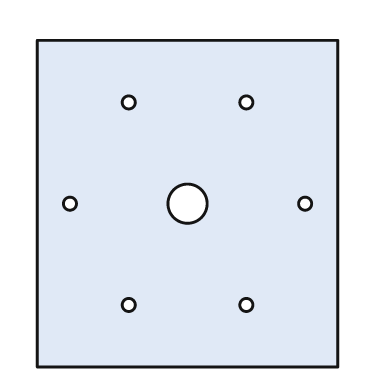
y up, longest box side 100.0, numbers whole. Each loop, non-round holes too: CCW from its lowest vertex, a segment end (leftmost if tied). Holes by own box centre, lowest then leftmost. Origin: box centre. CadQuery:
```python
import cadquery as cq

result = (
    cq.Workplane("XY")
    .moveTo(-46.0, -50.0)
    .lineTo(46.0, -50.0)
    .lineTo(46.0, 50.0)
    .lineTo(-46.0, 50.0)
    .close()
    .moveTo(-18.0, -31.0)
    .circle(2.0)
    .moveTo(18.0, -31.0)
    .circle(2.0)
    .moveTo(-36.0, 0.0)
    .circle(2.0)
    .moveTo(0.0, 0.0)
    .circle(6.0)
    .moveTo(36.0, 0.0)
    .circle(2.0)
    .moveTo(-18.0, 31.0)
    .circle(2.0)
    .moveTo(18.0, 31.0)
    .circle(2.0)
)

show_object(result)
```